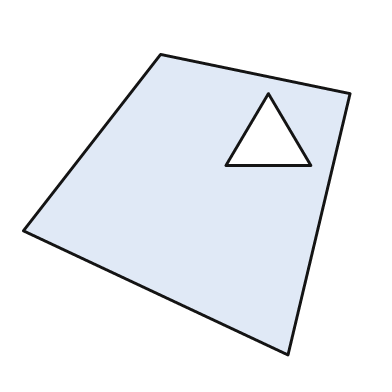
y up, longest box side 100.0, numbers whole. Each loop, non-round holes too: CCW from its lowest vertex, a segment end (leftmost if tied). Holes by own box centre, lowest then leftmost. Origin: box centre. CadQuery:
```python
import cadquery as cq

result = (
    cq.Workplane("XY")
    .moveTo(31.0, -46.0)
    .lineTo(50.0, 34.0)
    .lineTo(-8.0, 46.0)
    .lineTo(-50.0, -8.0)
    .close()
    .moveTo(12.0, 12.0)
    .lineTo(38.0, 12.0)
    .lineTo(25.0, 34.0)
    .close()
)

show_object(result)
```